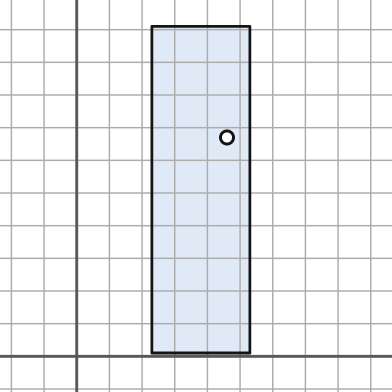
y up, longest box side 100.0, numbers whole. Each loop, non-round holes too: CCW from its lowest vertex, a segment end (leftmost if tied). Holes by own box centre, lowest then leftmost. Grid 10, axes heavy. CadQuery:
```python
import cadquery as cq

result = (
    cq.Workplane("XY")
    .moveTo(23.0, 1.0)
    .lineTo(53.0, 1.0)
    .lineTo(53.0, 101.0)
    .lineTo(23.0, 101.0)
    .close()
    .moveTo(46.0, 67.0)
    .circle(2.0)
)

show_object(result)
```